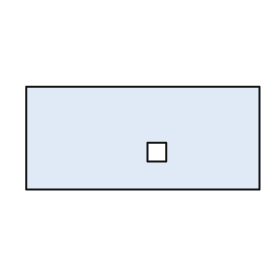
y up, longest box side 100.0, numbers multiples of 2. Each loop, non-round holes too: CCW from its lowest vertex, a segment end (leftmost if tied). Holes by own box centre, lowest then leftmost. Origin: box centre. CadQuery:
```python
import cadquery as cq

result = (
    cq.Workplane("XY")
    .moveTo(-50.0, -22.0)
    .lineTo(50.0, -22.0)
    .lineTo(50.0, 22.0)
    .lineTo(-50.0, 22.0)
    .close()
    .moveTo(2.0, -10.0)
    .lineTo(10.0, -10.0)
    .lineTo(10.0, -2.0)
    .lineTo(2.0, -2.0)
    .close()
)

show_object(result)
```